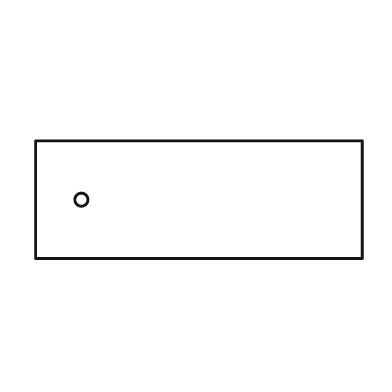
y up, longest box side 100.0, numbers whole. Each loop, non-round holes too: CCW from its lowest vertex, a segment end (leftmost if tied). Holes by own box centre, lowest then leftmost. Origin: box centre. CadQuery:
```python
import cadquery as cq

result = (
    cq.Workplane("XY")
    .moveTo(-50.0, -18.0)
    .lineTo(50.0, -18.0)
    .lineTo(50.0, 18.0)
    .lineTo(-50.0, 18.0)
    .close()
    .moveTo(-36.0, 0.0)
    .circle(2.0)
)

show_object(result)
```